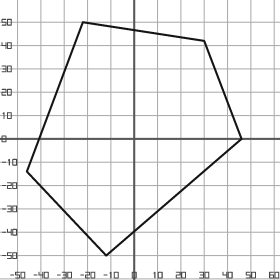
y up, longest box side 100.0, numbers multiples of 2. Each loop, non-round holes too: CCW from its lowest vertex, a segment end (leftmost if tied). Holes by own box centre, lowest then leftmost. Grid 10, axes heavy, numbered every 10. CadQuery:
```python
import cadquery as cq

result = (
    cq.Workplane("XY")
    .moveTo(-12.0, -50.0)
    .lineTo(46.0, 0.0)
    .lineTo(30.0, 42.0)
    .lineTo(-22.0, 50.0)
    .lineTo(-46.0, -14.0)
    .close()
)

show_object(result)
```